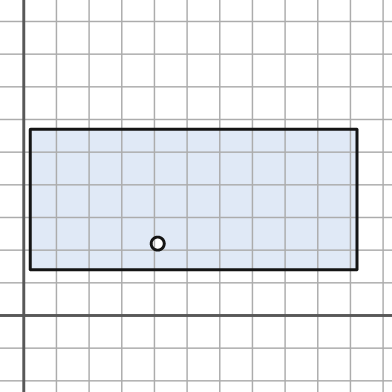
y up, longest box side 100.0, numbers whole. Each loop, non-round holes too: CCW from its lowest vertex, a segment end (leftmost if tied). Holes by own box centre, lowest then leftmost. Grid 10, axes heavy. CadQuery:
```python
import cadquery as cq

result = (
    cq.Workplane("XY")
    .moveTo(2.0, 14.0)
    .lineTo(102.0, 14.0)
    .lineTo(102.0, 57.0)
    .lineTo(2.0, 57.0)
    .close()
    .moveTo(41.0, 22.0)
    .circle(2.0)
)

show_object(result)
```